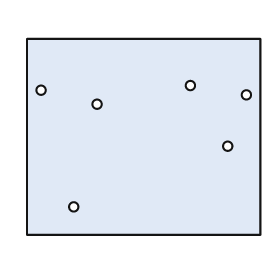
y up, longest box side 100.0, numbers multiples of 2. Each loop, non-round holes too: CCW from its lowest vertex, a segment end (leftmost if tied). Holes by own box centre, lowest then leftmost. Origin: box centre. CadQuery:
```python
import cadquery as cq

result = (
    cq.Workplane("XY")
    .moveTo(-50.0, -42.0)
    .lineTo(50.0, -42.0)
    .lineTo(50.0, 42.0)
    .lineTo(-50.0, 42.0)
    .close()
    .moveTo(-30.0, -30.0)
    .circle(2.0)
    .moveTo(36.0, -4.0)
    .circle(2.0)
    .moveTo(-20.0, 14.0)
    .circle(2.0)
    .moveTo(44.0, 18.0)
    .circle(2.0)
    .moveTo(-44.0, 20.0)
    .circle(2.0)
    .moveTo(20.0, 22.0)
    .circle(2.0)
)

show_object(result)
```